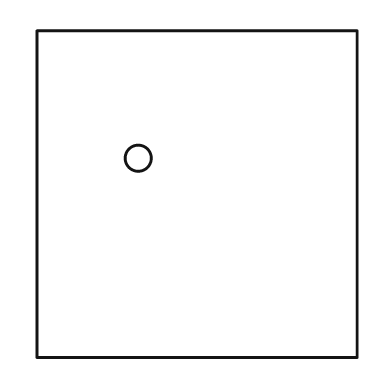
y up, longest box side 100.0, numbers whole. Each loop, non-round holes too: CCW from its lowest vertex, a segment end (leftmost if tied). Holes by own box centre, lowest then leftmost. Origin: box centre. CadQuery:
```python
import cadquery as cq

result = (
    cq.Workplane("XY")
    .moveTo(-49.0, -50.0)
    .lineTo(49.0, -50.0)
    .lineTo(49.0, 50.0)
    .lineTo(-49.0, 50.0)
    .close()
    .moveTo(-18.0, 11.0)
    .circle(4.0)
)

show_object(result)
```